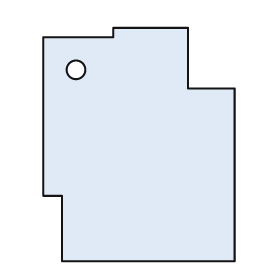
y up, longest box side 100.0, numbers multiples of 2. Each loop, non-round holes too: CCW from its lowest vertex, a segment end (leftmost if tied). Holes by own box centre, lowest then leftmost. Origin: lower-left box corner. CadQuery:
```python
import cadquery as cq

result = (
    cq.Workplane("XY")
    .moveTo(8.0, 0.0)
    .lineTo(82.0, 0.0)
    .lineTo(82.0, 74.0)
    .lineTo(62.0, 74.0)
    .lineTo(62.0, 100.0)
    .lineTo(30.0, 100.0)
    .lineTo(30.0, 96.0)
    .lineTo(0.0, 96.0)
    .lineTo(0.0, 28.0)
    .lineTo(8.0, 28.0)
    .close()
    .moveTo(14.0, 82.0)
    .circle(4.0)
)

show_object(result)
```